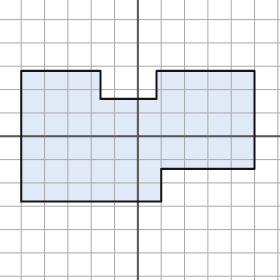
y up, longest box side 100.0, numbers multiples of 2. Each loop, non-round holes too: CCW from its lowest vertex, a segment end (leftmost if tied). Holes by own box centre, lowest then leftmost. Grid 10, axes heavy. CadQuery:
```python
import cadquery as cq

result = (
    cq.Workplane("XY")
    .moveTo(-50.0, -28.0)
    .lineTo(10.0, -28.0)
    .lineTo(10.0, -14.0)
    .lineTo(50.0, -14.0)
    .lineTo(50.0, 28.0)
    .lineTo(8.0, 28.0)
    .lineTo(8.0, 16.0)
    .lineTo(-16.0, 16.0)
    .lineTo(-16.0, 28.0)
    .lineTo(-50.0, 28.0)
    .close()
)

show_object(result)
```